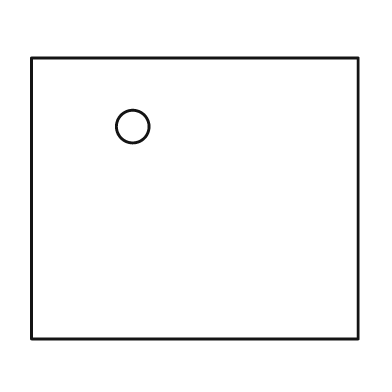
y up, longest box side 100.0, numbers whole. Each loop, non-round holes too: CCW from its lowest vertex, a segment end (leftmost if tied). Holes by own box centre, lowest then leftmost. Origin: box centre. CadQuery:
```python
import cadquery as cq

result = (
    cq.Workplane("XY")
    .moveTo(-50.0, -43.0)
    .lineTo(50.0, -43.0)
    .lineTo(50.0, 43.0)
    .lineTo(-50.0, 43.0)
    .close()
    .moveTo(-19.0, 22.0)
    .circle(5.0)
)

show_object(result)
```